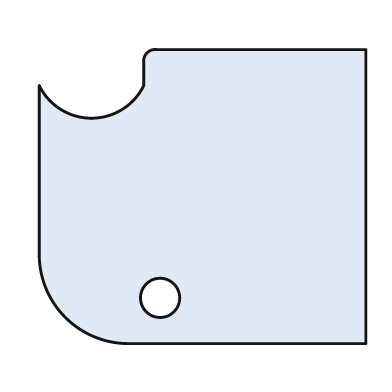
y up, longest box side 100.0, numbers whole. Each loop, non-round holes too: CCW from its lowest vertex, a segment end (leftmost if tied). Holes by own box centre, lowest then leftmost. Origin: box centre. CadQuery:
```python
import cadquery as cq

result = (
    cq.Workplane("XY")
    .moveTo(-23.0, -45.0)
    .lineTo(50.0, -45.0)
    .lineTo(50.0, 45.0)
    .lineTo(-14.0, 45.0)
    .threePointArc((-17.0, 44.0), (-18.0, 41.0))
    .lineTo(-18.0, 34.0)
    .threePointArc((-34.0, 24.0), (-50.0, 34.0))
    .lineTo(-50.0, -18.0)
    .threePointArc((-42.0, -37.0), (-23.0, -45.0))
    .close()
    .moveTo(-13.0, -31.0)
    .circle(6.0)
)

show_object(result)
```